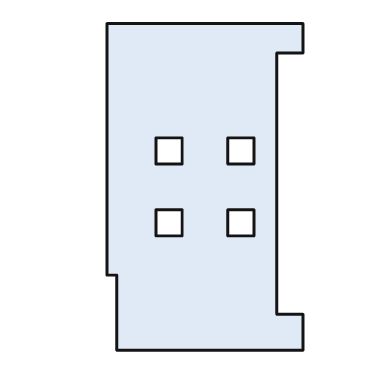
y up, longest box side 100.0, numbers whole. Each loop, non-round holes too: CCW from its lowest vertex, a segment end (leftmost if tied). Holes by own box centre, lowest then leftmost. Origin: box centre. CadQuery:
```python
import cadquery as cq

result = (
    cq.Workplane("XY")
    .moveTo(-27.0, -50.0)
    .lineTo(30.0, -50.0)
    .lineTo(30.0, -39.0)
    .lineTo(22.0, -39.0)
    .lineTo(22.0, 41.0)
    .lineTo(30.0, 41.0)
    .lineTo(30.0, 50.0)
    .lineTo(-30.0, 50.0)
    .lineTo(-30.0, -27.0)
    .lineTo(-27.0, -27.0)
    .close()
    .moveTo(-15.0, -15.0)
    .lineTo(-7.0, -15.0)
    .lineTo(-7.0, -7.0)
    .lineTo(-15.0, -7.0)
    .close()
    .moveTo(7.0, -15.0)
    .lineTo(15.0, -15.0)
    .lineTo(15.0, -7.0)
    .lineTo(7.0, -7.0)
    .close()
    .moveTo(-15.0, 7.0)
    .lineTo(-7.0, 7.0)
    .lineTo(-7.0, 15.0)
    .lineTo(-15.0, 15.0)
    .close()
    .moveTo(7.0, 7.0)
    .lineTo(15.0, 7.0)
    .lineTo(15.0, 15.0)
    .lineTo(7.0, 15.0)
    .close()
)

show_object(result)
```